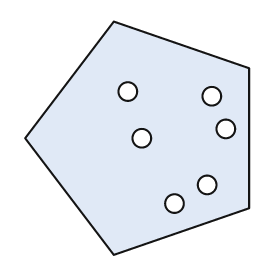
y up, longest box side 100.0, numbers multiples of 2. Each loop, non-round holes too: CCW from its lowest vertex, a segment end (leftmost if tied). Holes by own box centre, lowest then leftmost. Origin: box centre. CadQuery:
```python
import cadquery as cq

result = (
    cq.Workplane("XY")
    .moveTo(-10.0, -50.0)
    .lineTo(48.0, -30.0)
    .lineTo(48.0, 30.0)
    .lineTo(-10.0, 50.0)
    .lineTo(-48.0, 0.0)
    .close()
    .moveTo(16.0, -28.0)
    .circle(4.0)
    .moveTo(30.0, -20.0)
    .circle(4.0)
    .moveTo(2.0, 0.0)
    .circle(4.0)
    .moveTo(38.0, 4.0)
    .circle(4.0)
    .moveTo(32.0, 18.0)
    .circle(4.0)
    .moveTo(-4.0, 20.0)
    .circle(4.0)
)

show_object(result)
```